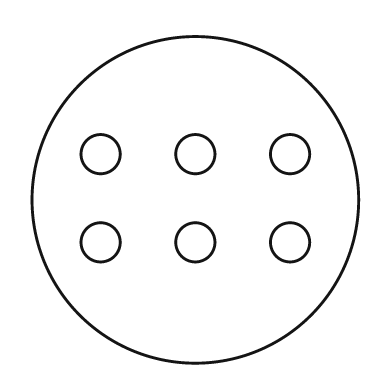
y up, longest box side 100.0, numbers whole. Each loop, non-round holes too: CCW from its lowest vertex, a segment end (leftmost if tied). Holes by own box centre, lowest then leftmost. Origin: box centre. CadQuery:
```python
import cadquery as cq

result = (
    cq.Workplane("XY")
    .moveTo(0.0, 0.0)
    .circle(50.0)
    .moveTo(-29.0, -13.0)
    .circle(6.0)
    .moveTo(0.0, -13.0)
    .circle(6.0)
    .moveTo(29.0, -13.0)
    .circle(6.0)
    .moveTo(-29.0, 14.0)
    .circle(6.0)
    .moveTo(0.0, 14.0)
    .circle(6.0)
    .moveTo(29.0, 14.0)
    .circle(6.0)
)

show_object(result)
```